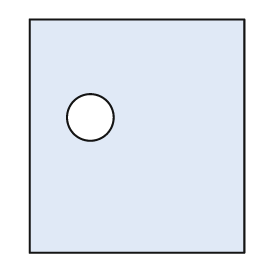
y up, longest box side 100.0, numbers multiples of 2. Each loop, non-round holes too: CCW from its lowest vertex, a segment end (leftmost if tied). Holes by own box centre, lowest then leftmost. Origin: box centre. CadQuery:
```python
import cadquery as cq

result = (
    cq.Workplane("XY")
    .moveTo(-46.0, -50.0)
    .lineTo(46.0, -50.0)
    .lineTo(46.0, 50.0)
    .lineTo(-46.0, 50.0)
    .close()
    .moveTo(-20.0, 8.0)
    .circle(10.0)
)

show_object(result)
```